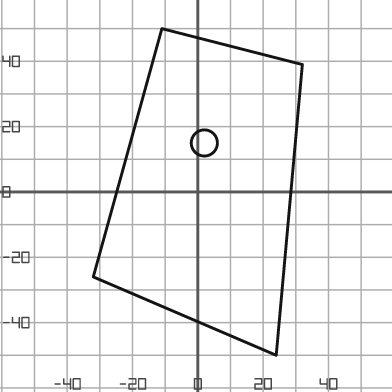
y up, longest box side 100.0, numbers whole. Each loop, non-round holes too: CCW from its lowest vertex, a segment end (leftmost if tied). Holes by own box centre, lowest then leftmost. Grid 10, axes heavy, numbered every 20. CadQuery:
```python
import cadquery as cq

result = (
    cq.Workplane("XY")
    .moveTo(24.0, -50.0)
    .lineTo(32.0, 39.0)
    .lineTo(-11.0, 50.0)
    .lineTo(-32.0, -26.0)
    .close()
    .moveTo(2.0, 15.0)
    .circle(4.0)
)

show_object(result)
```